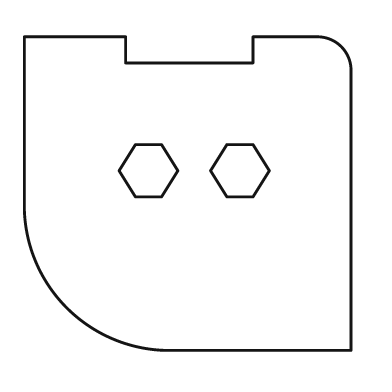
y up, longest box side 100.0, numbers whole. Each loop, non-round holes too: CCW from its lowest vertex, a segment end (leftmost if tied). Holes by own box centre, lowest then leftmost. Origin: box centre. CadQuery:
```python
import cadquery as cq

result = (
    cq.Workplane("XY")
    .moveTo(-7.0, -48.0)
    .lineTo(50.0, -48.0)
    .lineTo(50.0, 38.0)
    .threePointArc((47.0, 45.0), (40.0, 48.0))
    .lineTo(20.0, 48.0)
    .lineTo(20.0, 40.0)
    .lineTo(-19.0, 40.0)
    .lineTo(-19.0, 48.0)
    .lineTo(-50.0, 48.0)
    .lineTo(-50.0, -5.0)
    .threePointArc((-37.0, -35.0), (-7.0, -48.0))
    .close()
    .moveTo(-16.0, -1.0)
    .lineTo(-8.0, -1.0)
    .lineTo(-3.0, 7.0)
    .lineTo(-8.0, 15.0)
    .lineTo(-16.0, 15.0)
    .lineTo(-21.0, 7.0)
    .close()
    .moveTo(12.0, -1.0)
    .lineTo(20.0, -1.0)
    .lineTo(25.0, 7.0)
    .lineTo(20.0, 15.0)
    .lineTo(12.0, 15.0)
    .lineTo(7.0, 7.0)
    .close()
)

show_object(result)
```